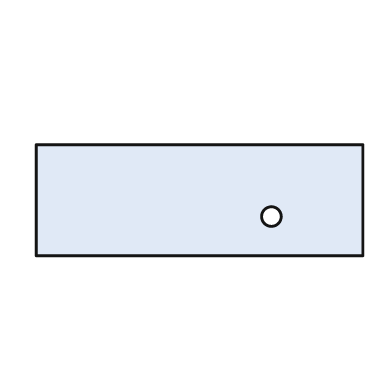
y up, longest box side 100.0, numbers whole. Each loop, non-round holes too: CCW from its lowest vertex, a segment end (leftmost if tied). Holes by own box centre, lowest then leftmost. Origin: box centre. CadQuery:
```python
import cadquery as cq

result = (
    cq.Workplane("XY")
    .moveTo(-50.0, -17.0)
    .lineTo(50.0, -17.0)
    .lineTo(50.0, 17.0)
    .lineTo(-50.0, 17.0)
    .close()
    .moveTo(22.0, -5.0)
    .circle(3.0)
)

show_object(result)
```